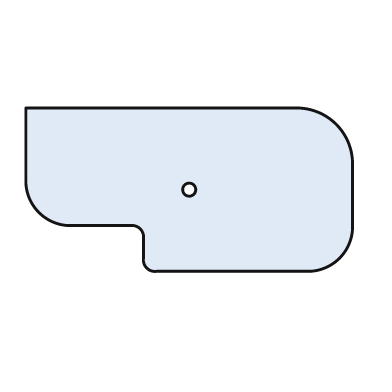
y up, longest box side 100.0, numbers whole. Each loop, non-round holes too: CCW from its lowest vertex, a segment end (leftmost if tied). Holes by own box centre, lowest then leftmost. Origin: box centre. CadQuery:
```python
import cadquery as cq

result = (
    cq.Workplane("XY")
    .moveTo(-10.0, -25.0)
    .lineTo(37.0, -25.0)
    .threePointArc((46.0, -21.0), (50.0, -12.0))
    .lineTo(50.0, 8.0)
    .threePointArc((45.0, 20.0), (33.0, 25.0))
    .lineTo(-50.0, 25.0)
    .lineTo(-50.0, 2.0)
    .threePointArc((-46.0, -7.0), (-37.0, -11.0))
    .lineTo(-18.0, -11.0)
    .threePointArc((-15.0, -12.0), (-14.0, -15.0))
    .lineTo(-14.0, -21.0)
    .threePointArc((-13.0, -24.0), (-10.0, -25.0))
    .close()
    .moveTo(0.0, 0.0)
    .circle(2.0)
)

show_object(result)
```